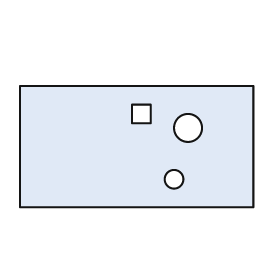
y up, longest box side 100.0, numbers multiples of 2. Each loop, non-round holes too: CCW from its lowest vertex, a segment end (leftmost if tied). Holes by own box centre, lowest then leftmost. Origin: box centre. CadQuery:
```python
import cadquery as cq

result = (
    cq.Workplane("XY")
    .moveTo(-50.0, -26.0)
    .lineTo(50.0, -26.0)
    .lineTo(50.0, 26.0)
    .lineTo(-50.0, 26.0)
    .close()
    .moveTo(16.0, -14.0)
    .circle(4.0)
    .moveTo(22.0, 8.0)
    .circle(6.0)
    .moveTo(-2.0, 10.0)
    .lineTo(6.0, 10.0)
    .lineTo(6.0, 18.0)
    .lineTo(-2.0, 18.0)
    .close()
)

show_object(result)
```